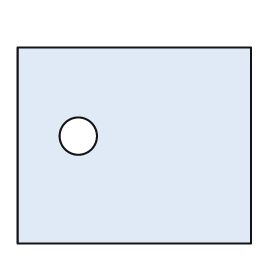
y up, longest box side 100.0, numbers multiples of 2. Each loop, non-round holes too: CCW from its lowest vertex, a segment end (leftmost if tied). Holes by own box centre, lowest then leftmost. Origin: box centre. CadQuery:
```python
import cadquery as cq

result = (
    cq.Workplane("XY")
    .moveTo(-50.0, -42.0)
    .lineTo(50.0, -42.0)
    .lineTo(50.0, 42.0)
    .lineTo(-50.0, 42.0)
    .close()
    .moveTo(-24.0, 4.0)
    .circle(8.0)
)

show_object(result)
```